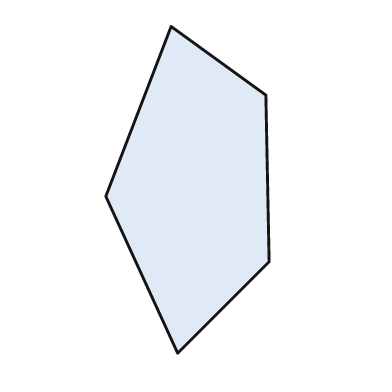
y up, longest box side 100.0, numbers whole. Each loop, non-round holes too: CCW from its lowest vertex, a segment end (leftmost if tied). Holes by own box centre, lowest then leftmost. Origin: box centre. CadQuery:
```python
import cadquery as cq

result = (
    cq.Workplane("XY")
    .moveTo(-3.0, -50.0)
    .lineTo(25.0, -22.0)
    .lineTo(24.0, 29.0)
    .lineTo(-5.0, 50.0)
    .lineTo(-25.0, -2.0)
    .close()
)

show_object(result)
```